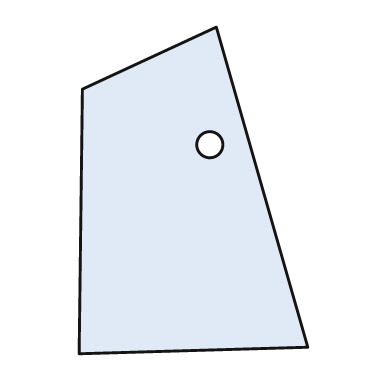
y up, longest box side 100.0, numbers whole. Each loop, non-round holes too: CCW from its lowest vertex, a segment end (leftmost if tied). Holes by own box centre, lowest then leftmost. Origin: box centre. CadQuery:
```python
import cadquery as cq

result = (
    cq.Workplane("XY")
    .moveTo(-35.0, -50.0)
    .lineTo(35.0, -48.0)
    .lineTo(7.0, 50.0)
    .lineTo(-34.0, 31.0)
    .close()
    .moveTo(5.0, 14.0)
    .circle(4.0)
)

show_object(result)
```